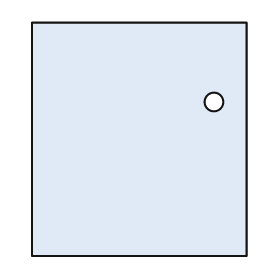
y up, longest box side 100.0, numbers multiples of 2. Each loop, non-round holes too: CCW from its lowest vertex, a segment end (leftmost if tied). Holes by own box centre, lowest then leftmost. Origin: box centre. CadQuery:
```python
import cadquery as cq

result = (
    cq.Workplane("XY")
    .moveTo(-46.0, -50.0)
    .lineTo(46.0, -50.0)
    .lineTo(46.0, 50.0)
    .lineTo(-46.0, 50.0)
    .close()
    .moveTo(32.0, 16.0)
    .circle(4.0)
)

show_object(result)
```